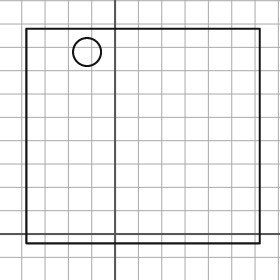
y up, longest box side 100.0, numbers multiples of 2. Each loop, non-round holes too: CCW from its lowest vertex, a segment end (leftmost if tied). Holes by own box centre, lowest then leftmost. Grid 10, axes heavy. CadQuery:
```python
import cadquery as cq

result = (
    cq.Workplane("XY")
    .moveTo(-38.0, -4.0)
    .lineTo(62.0, -4.0)
    .lineTo(62.0, 88.0)
    .lineTo(-38.0, 88.0)
    .close()
    .moveTo(-12.0, 78.0)
    .circle(6.0)
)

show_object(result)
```